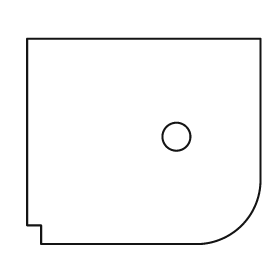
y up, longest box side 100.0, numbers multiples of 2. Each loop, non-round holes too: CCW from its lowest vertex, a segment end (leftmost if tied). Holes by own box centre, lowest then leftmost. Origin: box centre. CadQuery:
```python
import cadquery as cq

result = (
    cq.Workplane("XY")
    .moveTo(-44.0, -44.0)
    .lineTo(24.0, -44.0)
    .threePointArc((42.0, -36.0), (50.0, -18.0))
    .lineTo(50.0, 44.0)
    .lineTo(-50.0, 44.0)
    .lineTo(-50.0, -36.0)
    .lineTo(-44.0, -36.0)
    .close()
    .moveTo(14.0, 2.0)
    .circle(6.0)
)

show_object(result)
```